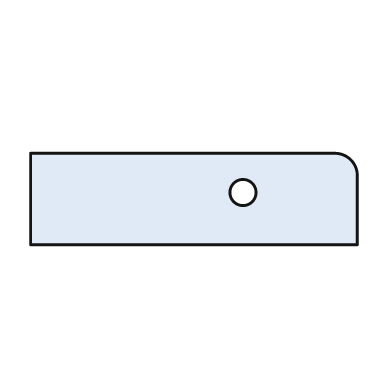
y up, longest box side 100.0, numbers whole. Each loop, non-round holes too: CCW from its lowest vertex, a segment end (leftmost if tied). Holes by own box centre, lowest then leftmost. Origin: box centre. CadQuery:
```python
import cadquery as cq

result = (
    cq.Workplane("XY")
    .moveTo(-50.0, -14.0)
    .lineTo(50.0, -14.0)
    .lineTo(50.0, 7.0)
    .threePointArc((48.0, 12.0), (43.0, 14.0))
    .lineTo(-50.0, 14.0)
    .close()
    .moveTo(15.0, 2.0)
    .circle(4.0)
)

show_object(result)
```